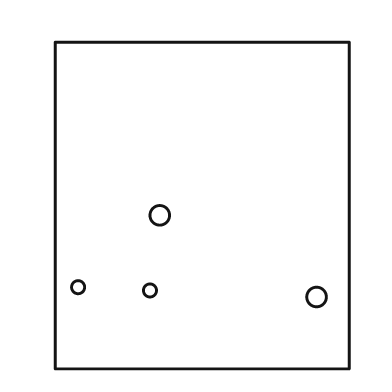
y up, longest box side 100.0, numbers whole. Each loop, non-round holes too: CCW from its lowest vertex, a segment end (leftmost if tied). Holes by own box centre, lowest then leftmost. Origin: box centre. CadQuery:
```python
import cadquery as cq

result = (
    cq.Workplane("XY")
    .moveTo(-45.0, -50.0)
    .lineTo(45.0, -50.0)
    .lineTo(45.0, 50.0)
    .lineTo(-45.0, 50.0)
    .close()
    .moveTo(35.0, -28.0)
    .circle(3.0)
    .moveTo(-16.0, -26.0)
    .circle(2.0)
    .moveTo(-38.0, -25.0)
    .circle(2.0)
    .moveTo(-13.0, -3.0)
    .circle(3.0)
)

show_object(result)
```